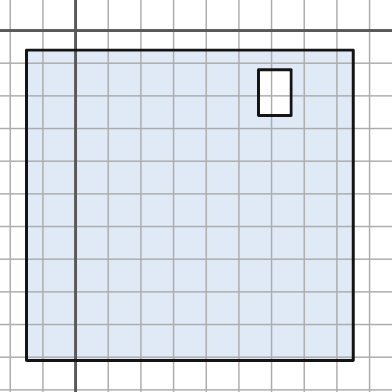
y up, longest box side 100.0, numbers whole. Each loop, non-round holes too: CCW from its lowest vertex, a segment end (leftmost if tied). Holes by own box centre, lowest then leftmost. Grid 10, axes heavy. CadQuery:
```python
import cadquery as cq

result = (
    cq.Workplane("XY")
    .moveTo(-15.0, -101.0)
    .lineTo(85.0, -101.0)
    .lineTo(85.0, -6.0)
    .lineTo(-15.0, -6.0)
    .close()
    .moveTo(56.0, -26.0)
    .lineTo(66.0, -26.0)
    .lineTo(66.0, -12.0)
    .lineTo(56.0, -12.0)
    .close()
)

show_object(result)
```